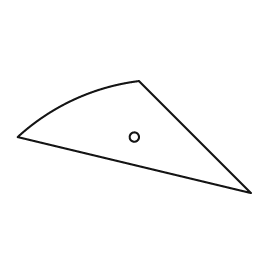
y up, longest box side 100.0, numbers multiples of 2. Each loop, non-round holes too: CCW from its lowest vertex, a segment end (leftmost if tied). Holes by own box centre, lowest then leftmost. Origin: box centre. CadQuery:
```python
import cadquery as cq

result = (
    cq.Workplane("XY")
    .moveTo(50.0, -24.0)
    .lineTo(2.0, 24.0)
    .threePointArc((-26.0, 16.0), (-50.0, 0.0))
    .close()
    .moveTo(0.0, 0.0)
    .circle(2.0)
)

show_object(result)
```